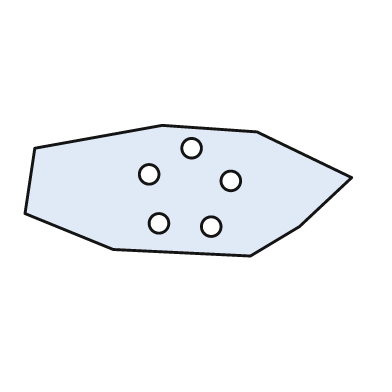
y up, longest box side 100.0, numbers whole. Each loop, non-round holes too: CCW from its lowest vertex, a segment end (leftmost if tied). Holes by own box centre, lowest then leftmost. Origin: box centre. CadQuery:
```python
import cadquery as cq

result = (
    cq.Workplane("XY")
    .moveTo(19.0, -20.0)
    .lineTo(34.0, -11.0)
    .lineTo(50.0, 4.0)
    .lineTo(21.0, 18.0)
    .lineTo(-8.0, 20.0)
    .lineTo(-47.0, 13.0)
    .lineTo(-50.0, -7.0)
    .lineTo(-23.0, -18.0)
    .close()
    .moveTo(7.0, -11.0)
    .circle(3.0)
    .moveTo(-9.0, -10.0)
    .circle(3.0)
    .moveTo(13.0, 3.0)
    .circle(3.0)
    .moveTo(-12.0, 5.0)
    .circle(3.0)
    .moveTo(1.0, 13.0)
    .circle(3.0)
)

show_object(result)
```